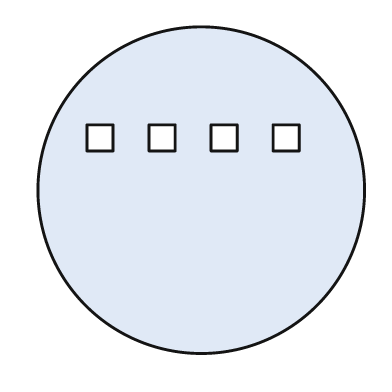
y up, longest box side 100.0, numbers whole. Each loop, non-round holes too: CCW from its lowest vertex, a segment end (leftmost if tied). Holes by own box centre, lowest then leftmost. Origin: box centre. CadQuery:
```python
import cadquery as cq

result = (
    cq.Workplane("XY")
    .moveTo(0.0, 0.0)
    .circle(50.0)
    .moveTo(-35.0, 12.0)
    .lineTo(-27.0, 12.0)
    .lineTo(-27.0, 20.0)
    .lineTo(-35.0, 20.0)
    .close()
    .moveTo(-16.0, 12.0)
    .lineTo(-8.0, 12.0)
    .lineTo(-8.0, 20.0)
    .lineTo(-16.0, 20.0)
    .close()
    .moveTo(3.0, 12.0)
    .lineTo(11.0, 12.0)
    .lineTo(11.0, 20.0)
    .lineTo(3.0, 20.0)
    .close()
    .moveTo(22.0, 12.0)
    .lineTo(30.0, 12.0)
    .lineTo(30.0, 20.0)
    .lineTo(22.0, 20.0)
    .close()
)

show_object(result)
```